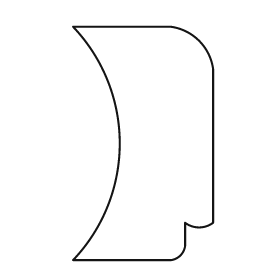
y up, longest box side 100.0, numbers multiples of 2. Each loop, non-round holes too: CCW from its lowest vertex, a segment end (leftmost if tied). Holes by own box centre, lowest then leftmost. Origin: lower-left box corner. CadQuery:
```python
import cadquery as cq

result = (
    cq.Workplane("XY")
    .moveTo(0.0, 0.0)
    .lineTo(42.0, 0.0)
    .threePointArc((46.0, 2.0), (48.0, 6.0))
    .lineTo(48.0, 16.0)
    .threePointArc((54.0, 14.0), (60.0, 16.0))
    .lineTo(60.0, 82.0)
    .threePointArc((54.0, 94.0), (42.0, 100.0))
    .lineTo(0.0, 100.0)
    .threePointArc((20.0, 50.0), (0.0, 0.0))
    .close()
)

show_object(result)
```